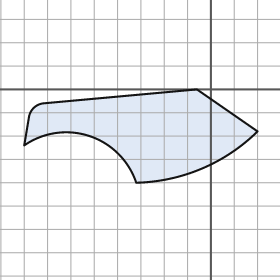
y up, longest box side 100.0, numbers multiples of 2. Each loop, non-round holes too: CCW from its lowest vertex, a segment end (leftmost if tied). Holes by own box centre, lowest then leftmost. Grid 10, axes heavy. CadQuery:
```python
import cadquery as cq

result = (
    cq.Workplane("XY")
    .moveTo(-32.0, -40.0)
    .threePointArc((-4.0, -34.0), (20.0, -18.0))
    .lineTo(-6.0, 0.0)
    .lineTo(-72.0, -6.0)
    .threePointArc((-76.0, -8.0), (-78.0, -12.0))
    .lineTo(-80.0, -24.0)
    .threePointArc((-52.0, -20.0), (-32.0, -40.0))
    .close()
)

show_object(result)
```